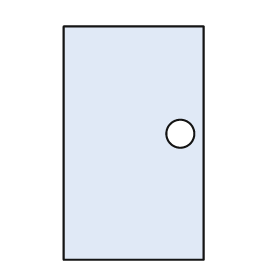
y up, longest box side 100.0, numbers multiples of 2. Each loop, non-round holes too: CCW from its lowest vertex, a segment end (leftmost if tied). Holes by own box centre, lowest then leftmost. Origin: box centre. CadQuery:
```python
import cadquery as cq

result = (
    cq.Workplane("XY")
    .moveTo(-30.0, -50.0)
    .lineTo(30.0, -50.0)
    .lineTo(30.0, 50.0)
    .lineTo(-30.0, 50.0)
    .close()
    .moveTo(20.0, 4.0)
    .circle(6.0)
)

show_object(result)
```